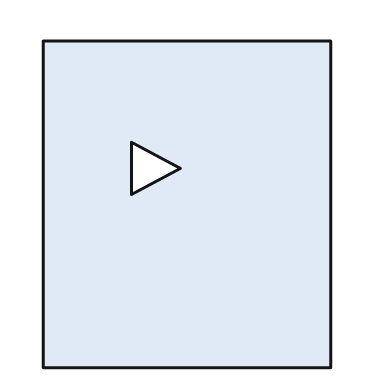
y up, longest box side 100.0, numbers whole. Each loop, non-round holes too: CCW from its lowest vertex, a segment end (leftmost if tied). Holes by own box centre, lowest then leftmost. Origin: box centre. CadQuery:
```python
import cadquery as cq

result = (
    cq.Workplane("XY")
    .moveTo(-44.0, -50.0)
    .lineTo(44.0, -50.0)
    .lineTo(44.0, 50.0)
    .lineTo(-44.0, 50.0)
    .close()
    .moveTo(-17.0, 3.0)
    .lineTo(-2.0, 11.0)
    .lineTo(-17.0, 19.0)
    .close()
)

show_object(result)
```